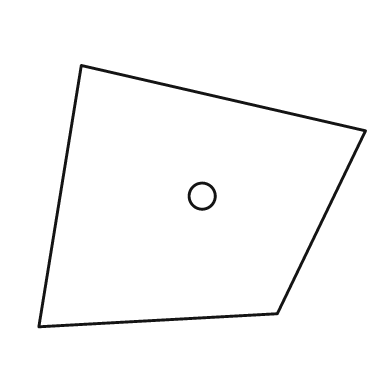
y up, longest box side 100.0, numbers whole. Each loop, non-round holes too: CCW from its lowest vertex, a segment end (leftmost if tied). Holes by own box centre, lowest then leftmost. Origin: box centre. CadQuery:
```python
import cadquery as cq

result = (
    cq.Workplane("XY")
    .moveTo(-50.0, -40.0)
    .lineTo(23.0, -36.0)
    .lineTo(50.0, 20.0)
    .lineTo(-37.0, 40.0)
    .close()
    .moveTo(0.0, 0.0)
    .circle(4.0)
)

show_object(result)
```